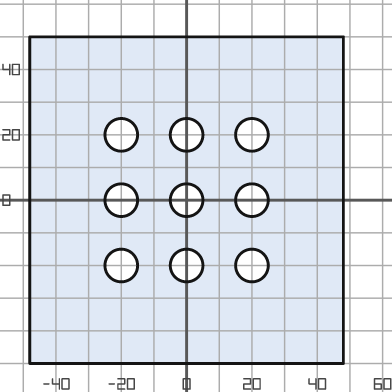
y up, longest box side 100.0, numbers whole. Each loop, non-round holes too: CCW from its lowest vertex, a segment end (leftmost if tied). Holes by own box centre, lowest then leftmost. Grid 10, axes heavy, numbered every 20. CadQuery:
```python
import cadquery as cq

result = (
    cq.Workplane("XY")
    .moveTo(-48.0, -50.0)
    .lineTo(48.0, -50.0)
    .lineTo(48.0, 50.0)
    .lineTo(-48.0, 50.0)
    .close()
    .moveTo(-20.0, -20.0)
    .circle(5.0)
    .moveTo(0.0, -20.0)
    .circle(5.0)
    .moveTo(20.0, -20.0)
    .circle(5.0)
    .moveTo(-20.0, 0.0)
    .circle(5.0)
    .moveTo(0.0, 0.0)
    .circle(5.0)
    .moveTo(20.0, 0.0)
    .circle(5.0)
    .moveTo(-20.0, 20.0)
    .circle(5.0)
    .moveTo(0.0, 20.0)
    .circle(5.0)
    .moveTo(20.0, 20.0)
    .circle(5.0)
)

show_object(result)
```